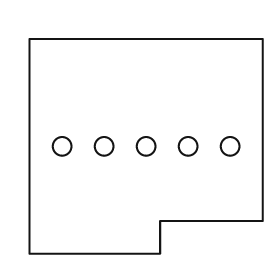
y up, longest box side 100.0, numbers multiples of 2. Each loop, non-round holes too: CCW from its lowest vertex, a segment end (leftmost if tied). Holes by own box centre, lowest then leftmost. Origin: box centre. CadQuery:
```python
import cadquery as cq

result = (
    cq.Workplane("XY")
    .moveTo(-50.0, -46.0)
    .lineTo(6.0, -46.0)
    .lineTo(6.0, -32.0)
    .lineTo(50.0, -32.0)
    .lineTo(50.0, 46.0)
    .lineTo(-50.0, 46.0)
    .close()
    .moveTo(-36.0, 0.0)
    .circle(4.0)
    .moveTo(-18.0, 0.0)
    .circle(4.0)
    .moveTo(0.0, 0.0)
    .circle(4.0)
    .moveTo(18.0, 0.0)
    .circle(4.0)
    .moveTo(36.0, 0.0)
    .circle(4.0)
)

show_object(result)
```